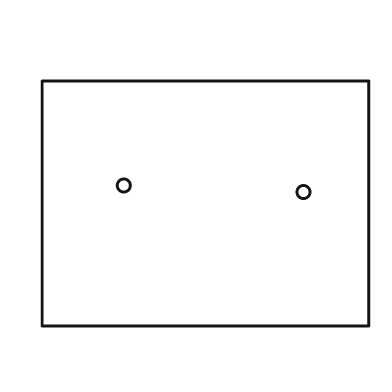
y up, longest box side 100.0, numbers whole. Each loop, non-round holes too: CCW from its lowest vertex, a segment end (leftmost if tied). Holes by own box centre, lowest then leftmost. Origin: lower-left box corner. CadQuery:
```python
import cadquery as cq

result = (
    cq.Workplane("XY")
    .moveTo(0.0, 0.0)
    .lineTo(100.0, 0.0)
    .lineTo(100.0, 75.0)
    .lineTo(0.0, 75.0)
    .close()
    .moveTo(80.0, 41.0)
    .circle(2.0)
    .moveTo(25.0, 43.0)
    .circle(2.0)
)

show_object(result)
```